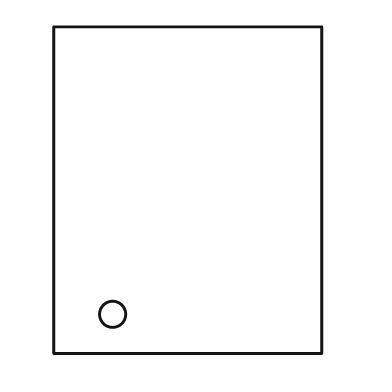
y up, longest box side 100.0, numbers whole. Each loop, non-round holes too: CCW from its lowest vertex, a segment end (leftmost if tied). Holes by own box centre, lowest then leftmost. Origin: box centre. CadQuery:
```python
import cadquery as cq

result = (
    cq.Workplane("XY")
    .moveTo(-41.0, -50.0)
    .lineTo(41.0, -50.0)
    .lineTo(41.0, 50.0)
    .lineTo(-41.0, 50.0)
    .close()
    .moveTo(-23.0, -38.0)
    .circle(4.0)
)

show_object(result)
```